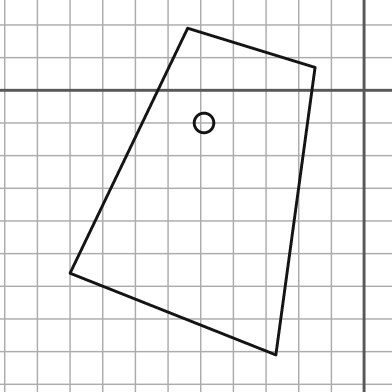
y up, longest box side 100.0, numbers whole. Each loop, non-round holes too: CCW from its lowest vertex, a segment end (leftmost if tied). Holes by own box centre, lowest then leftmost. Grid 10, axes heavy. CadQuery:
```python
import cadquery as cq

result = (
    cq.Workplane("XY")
    .moveTo(-27.0, -81.0)
    .lineTo(-15.0, 7.0)
    .lineTo(-54.0, 19.0)
    .lineTo(-90.0, -56.0)
    .close()
    .moveTo(-49.0, -10.0)
    .circle(3.0)
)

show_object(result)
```